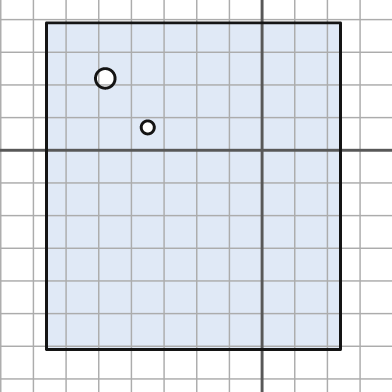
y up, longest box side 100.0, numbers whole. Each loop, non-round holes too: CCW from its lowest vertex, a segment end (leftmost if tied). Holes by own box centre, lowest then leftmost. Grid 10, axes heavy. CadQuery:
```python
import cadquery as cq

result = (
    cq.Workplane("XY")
    .moveTo(-66.0, -61.0)
    .lineTo(24.0, -61.0)
    .lineTo(24.0, 39.0)
    .lineTo(-66.0, 39.0)
    .close()
    .moveTo(-35.0, 7.0)
    .circle(2.0)
    .moveTo(-48.0, 22.0)
    .circle(3.0)
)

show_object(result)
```